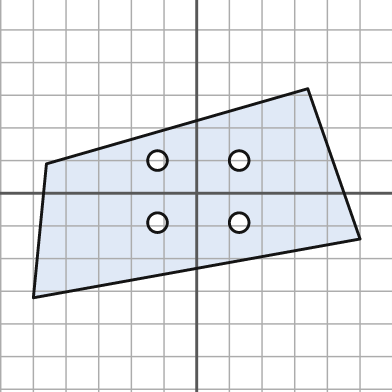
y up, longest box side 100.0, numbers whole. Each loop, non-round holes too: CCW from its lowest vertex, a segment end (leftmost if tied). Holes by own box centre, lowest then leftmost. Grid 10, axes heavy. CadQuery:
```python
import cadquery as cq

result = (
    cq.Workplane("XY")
    .moveTo(-50.0, -32.0)
    .lineTo(50.0, -14.0)
    .lineTo(34.0, 32.0)
    .lineTo(-46.0, 9.0)
    .close()
    .moveTo(-12.0, -9.0)
    .circle(3.0)
    .moveTo(13.0, -9.0)
    .circle(3.0)
    .moveTo(-12.0, 10.0)
    .circle(3.0)
    .moveTo(13.0, 10.0)
    .circle(3.0)
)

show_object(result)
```